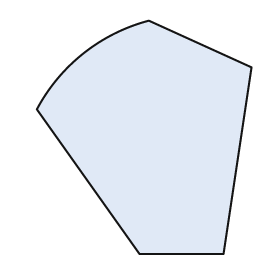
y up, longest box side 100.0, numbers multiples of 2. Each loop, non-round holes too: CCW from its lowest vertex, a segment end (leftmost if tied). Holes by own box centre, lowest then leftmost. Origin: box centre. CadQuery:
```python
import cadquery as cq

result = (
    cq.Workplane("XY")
    .moveTo(-2.0, -50.0)
    .lineTo(34.0, -50.0)
    .lineTo(46.0, 30.0)
    .lineTo(2.0, 50.0)
    .threePointArc((-26.0, 36.0), (-46.0, 12.0))
    .close()
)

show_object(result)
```